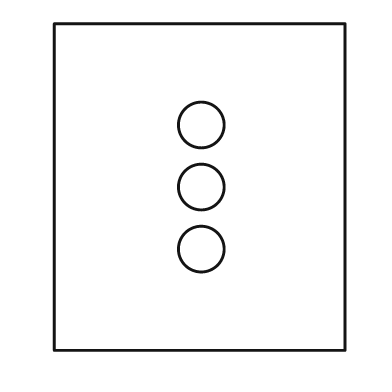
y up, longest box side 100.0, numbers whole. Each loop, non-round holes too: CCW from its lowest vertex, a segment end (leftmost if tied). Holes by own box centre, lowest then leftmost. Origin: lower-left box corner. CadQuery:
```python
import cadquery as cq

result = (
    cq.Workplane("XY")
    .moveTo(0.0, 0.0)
    .lineTo(89.0, 0.0)
    .lineTo(89.0, 100.0)
    .lineTo(0.0, 100.0)
    .close()
    .moveTo(45.0, 31.0)
    .circle(7.0)
    .moveTo(45.0, 50.0)
    .circle(7.0)
    .moveTo(45.0, 69.0)
    .circle(7.0)
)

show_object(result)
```